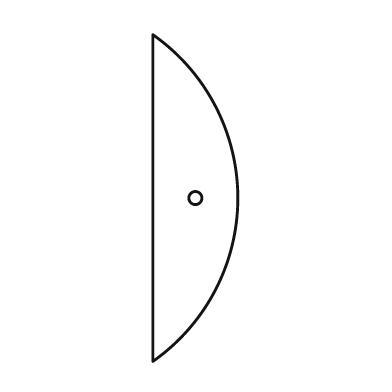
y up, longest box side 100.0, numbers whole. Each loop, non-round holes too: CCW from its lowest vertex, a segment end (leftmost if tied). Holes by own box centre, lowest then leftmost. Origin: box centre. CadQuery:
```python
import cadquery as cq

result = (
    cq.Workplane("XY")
    .moveTo(-13.0, -50.0)
    .threePointArc((13.0, 0.0), (-13.0, 50.0))
    .close()
    .moveTo(0.0, 0.0)
    .circle(2.0)
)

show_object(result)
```